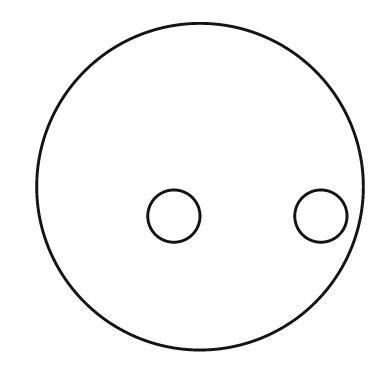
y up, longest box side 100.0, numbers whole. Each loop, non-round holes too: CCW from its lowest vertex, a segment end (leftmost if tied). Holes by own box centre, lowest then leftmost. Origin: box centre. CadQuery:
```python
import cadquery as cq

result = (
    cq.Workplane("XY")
    .moveTo(0.0, 0.0)
    .circle(50.0)
    .moveTo(-8.0, -9.0)
    .circle(8.0)
    .moveTo(37.0, -9.0)
    .circle(8.0)
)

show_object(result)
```